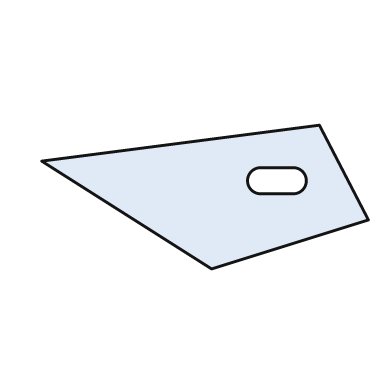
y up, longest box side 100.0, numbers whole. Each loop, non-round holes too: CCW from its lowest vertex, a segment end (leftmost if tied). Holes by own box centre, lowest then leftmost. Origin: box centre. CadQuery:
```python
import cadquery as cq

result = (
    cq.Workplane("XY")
    .moveTo(2.0, -22.0)
    .lineTo(50.0, -7.0)
    .lineTo(35.0, 22.0)
    .lineTo(-50.0, 11.0)
    .close()
    .moveTo(17.0, 1.0)
    .lineTo(27.0, 1.0)
    .threePointArc((31.0, 5.0), (27.0, 9.0))
    .lineTo(17.0, 9.0)
    .threePointArc((13.0, 5.0), (17.0, 1.0))
    .close()
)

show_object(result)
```